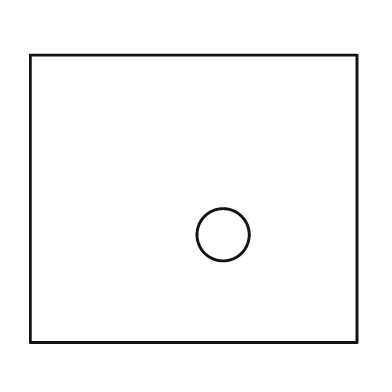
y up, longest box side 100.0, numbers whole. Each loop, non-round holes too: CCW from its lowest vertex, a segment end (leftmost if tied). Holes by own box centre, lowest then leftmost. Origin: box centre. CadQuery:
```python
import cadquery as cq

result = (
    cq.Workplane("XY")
    .moveTo(-50.0, -44.0)
    .lineTo(50.0, -44.0)
    .lineTo(50.0, 44.0)
    .lineTo(-50.0, 44.0)
    .close()
    .moveTo(9.0, -11.0)
    .circle(8.0)
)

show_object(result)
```